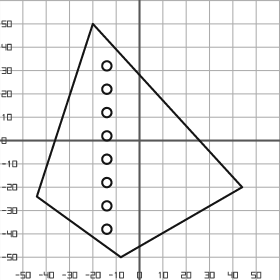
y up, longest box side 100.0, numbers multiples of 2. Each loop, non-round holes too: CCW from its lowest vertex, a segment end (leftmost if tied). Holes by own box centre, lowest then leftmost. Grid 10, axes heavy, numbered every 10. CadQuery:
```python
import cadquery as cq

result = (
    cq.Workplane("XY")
    .moveTo(-8.0, -50.0)
    .lineTo(44.0, -20.0)
    .lineTo(-20.0, 50.0)
    .lineTo(-44.0, -24.0)
    .close()
    .moveTo(-14.0, -38.0)
    .circle(2.0)
    .moveTo(-14.0, -28.0)
    .circle(2.0)
    .moveTo(-14.0, -18.0)
    .circle(2.0)
    .moveTo(-14.0, -8.0)
    .circle(2.0)
    .moveTo(-14.0, 2.0)
    .circle(2.0)
    .moveTo(-14.0, 12.0)
    .circle(2.0)
    .moveTo(-14.0, 22.0)
    .circle(2.0)
    .moveTo(-14.0, 32.0)
    .circle(2.0)
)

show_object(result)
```